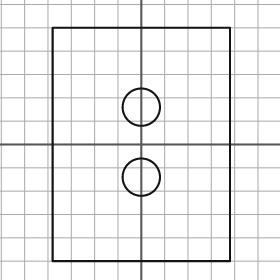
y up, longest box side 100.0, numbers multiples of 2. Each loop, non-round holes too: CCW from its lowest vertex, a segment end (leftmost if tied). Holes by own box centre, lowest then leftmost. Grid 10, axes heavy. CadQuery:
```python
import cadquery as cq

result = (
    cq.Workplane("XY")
    .moveTo(-38.0, -50.0)
    .lineTo(38.0, -50.0)
    .lineTo(38.0, 50.0)
    .lineTo(-38.0, 50.0)
    .close()
    .moveTo(0.0, -14.0)
    .circle(8.0)
    .moveTo(0.0, 16.0)
    .circle(8.0)
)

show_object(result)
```